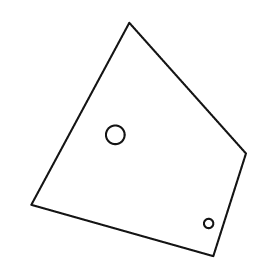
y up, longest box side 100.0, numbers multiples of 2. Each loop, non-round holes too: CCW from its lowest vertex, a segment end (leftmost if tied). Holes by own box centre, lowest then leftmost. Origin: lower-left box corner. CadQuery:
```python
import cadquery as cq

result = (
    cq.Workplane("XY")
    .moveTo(78.0, 0.0)
    .lineTo(92.0, 44.0)
    .lineTo(42.0, 100.0)
    .lineTo(0.0, 22.0)
    .close()
    .moveTo(76.0, 14.0)
    .circle(2.0)
    .moveTo(36.0, 52.0)
    .circle(4.0)
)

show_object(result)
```